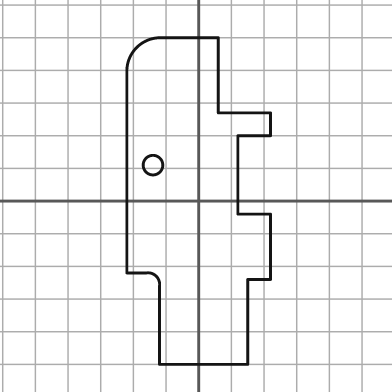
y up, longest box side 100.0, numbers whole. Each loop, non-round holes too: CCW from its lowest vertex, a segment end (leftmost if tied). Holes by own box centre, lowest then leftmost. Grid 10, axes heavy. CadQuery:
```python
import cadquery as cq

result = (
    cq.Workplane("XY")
    .moveTo(-12.0, -50.0)
    .lineTo(15.0, -50.0)
    .lineTo(15.0, -24.0)
    .lineTo(22.0, -24.0)
    .lineTo(22.0, -4.0)
    .lineTo(12.0, -4.0)
    .lineTo(12.0, 20.0)
    .lineTo(22.0, 20.0)
    .lineTo(22.0, 27.0)
    .lineTo(6.0, 27.0)
    .lineTo(6.0, 50.0)
    .lineTo(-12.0, 50.0)
    .threePointArc((-19.0, 47.0), (-22.0, 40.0))
    .lineTo(-22.0, -22.0)
    .lineTo(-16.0, -22.0)
    .threePointArc((-13.0, -23.0), (-12.0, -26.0))
    .close()
    .moveTo(-14.0, 11.0)
    .circle(3.0)
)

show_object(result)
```